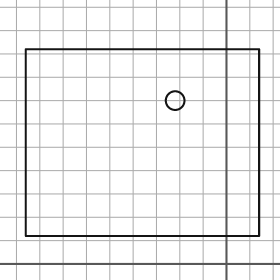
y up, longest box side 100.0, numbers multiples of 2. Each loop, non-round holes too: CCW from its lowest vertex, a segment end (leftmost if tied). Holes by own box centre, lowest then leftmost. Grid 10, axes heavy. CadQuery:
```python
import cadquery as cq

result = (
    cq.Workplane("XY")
    .moveTo(-86.0, 12.0)
    .lineTo(14.0, 12.0)
    .lineTo(14.0, 92.0)
    .lineTo(-86.0, 92.0)
    .close()
    .moveTo(-22.0, 70.0)
    .circle(4.0)
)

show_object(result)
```